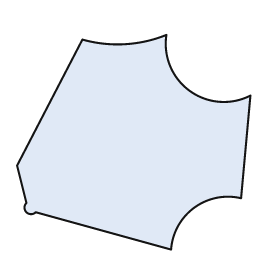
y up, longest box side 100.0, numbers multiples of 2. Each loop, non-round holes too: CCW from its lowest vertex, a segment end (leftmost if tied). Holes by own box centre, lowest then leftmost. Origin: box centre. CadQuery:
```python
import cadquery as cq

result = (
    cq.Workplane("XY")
    .moveTo(16.0, -46.0)
    .threePointArc((26.0, -28.0), (46.0, -24.0))
    .lineTo(50.0, 20.0)
    .threePointArc((24.0, 22.0), (14.0, 46.0))
    .threePointArc((-4.0, 42.0), (-22.0, 44.0))
    .lineTo(-50.0, -10.0)
    .lineTo(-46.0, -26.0)
    .threePointArc((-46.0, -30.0), (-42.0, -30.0))
    .close()
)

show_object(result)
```